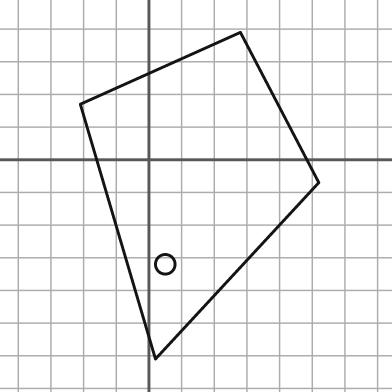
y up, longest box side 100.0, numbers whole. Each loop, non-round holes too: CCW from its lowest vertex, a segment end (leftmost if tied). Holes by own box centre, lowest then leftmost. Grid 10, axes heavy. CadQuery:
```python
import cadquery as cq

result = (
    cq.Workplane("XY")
    .moveTo(2.0, -61.0)
    .lineTo(52.0, -7.0)
    .lineTo(28.0, 39.0)
    .lineTo(-21.0, 17.0)
    .close()
    .moveTo(5.0, -32.0)
    .circle(3.0)
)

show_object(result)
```